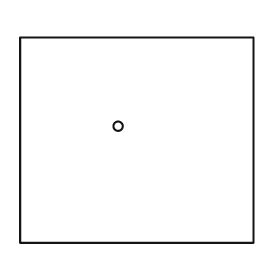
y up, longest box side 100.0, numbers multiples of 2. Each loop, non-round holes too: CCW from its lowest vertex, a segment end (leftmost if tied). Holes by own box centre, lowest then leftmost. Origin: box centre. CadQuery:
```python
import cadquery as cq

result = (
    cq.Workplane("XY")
    .moveTo(-50.0, -44.0)
    .lineTo(50.0, -44.0)
    .lineTo(50.0, 44.0)
    .lineTo(-50.0, 44.0)
    .close()
    .moveTo(-8.0, 6.0)
    .circle(2.0)
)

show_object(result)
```